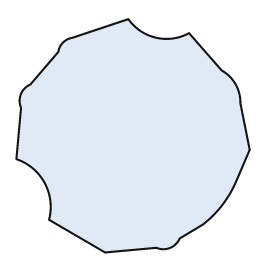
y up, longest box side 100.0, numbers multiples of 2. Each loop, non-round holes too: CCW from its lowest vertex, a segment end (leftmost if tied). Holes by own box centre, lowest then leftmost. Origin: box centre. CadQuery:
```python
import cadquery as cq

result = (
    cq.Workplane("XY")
    .moveTo(-12.0, -50.0)
    .lineTo(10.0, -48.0)
    .threePointArc((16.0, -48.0), (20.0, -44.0))
    .lineTo(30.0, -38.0)
    .threePointArc((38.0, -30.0), (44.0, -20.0))
    .lineTo(50.0, -6.0)
    .lineTo(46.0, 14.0)
    .threePointArc((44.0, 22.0), (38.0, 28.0))
    .lineTo(24.0, 44.0)
    .threePointArc((10.0, 42.0), (-2.0, 50.0))
    .lineTo(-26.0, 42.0)
    .threePointArc((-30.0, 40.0), (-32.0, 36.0))
    .lineTo(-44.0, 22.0)
    .threePointArc((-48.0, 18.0), (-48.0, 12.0))
    .lineTo(-50.0, -10.0)
    .threePointArc((-38.0, -20.0), (-36.0, -36.0))
    .close()
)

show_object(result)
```